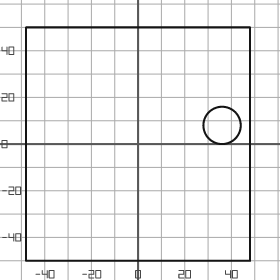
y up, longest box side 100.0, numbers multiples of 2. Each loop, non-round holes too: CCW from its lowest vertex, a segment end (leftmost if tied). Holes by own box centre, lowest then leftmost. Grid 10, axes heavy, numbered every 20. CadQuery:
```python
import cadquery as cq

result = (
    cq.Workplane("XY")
    .moveTo(-48.0, -50.0)
    .lineTo(48.0, -50.0)
    .lineTo(48.0, 50.0)
    .lineTo(-48.0, 50.0)
    .close()
    .moveTo(36.0, 8.0)
    .circle(8.0)
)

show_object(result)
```